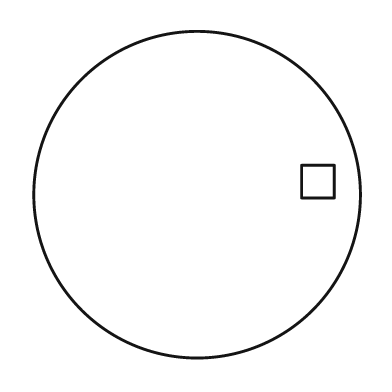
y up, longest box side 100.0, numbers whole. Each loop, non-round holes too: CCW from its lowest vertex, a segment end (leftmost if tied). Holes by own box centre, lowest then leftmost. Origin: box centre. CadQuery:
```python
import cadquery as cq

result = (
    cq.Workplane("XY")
    .moveTo(0.0, 0.0)
    .circle(50.0)
    .moveTo(32.0, -1.0)
    .lineTo(42.0, -1.0)
    .lineTo(42.0, 9.0)
    .lineTo(32.0, 9.0)
    .close()
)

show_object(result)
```